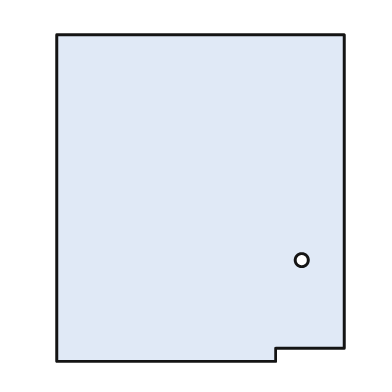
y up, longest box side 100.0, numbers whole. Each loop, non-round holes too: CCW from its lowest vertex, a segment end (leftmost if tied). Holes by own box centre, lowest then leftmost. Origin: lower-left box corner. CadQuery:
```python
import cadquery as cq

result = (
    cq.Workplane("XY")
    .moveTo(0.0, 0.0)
    .lineTo(67.0, 0.0)
    .lineTo(67.0, 4.0)
    .lineTo(88.0, 4.0)
    .lineTo(88.0, 100.0)
    .lineTo(0.0, 100.0)
    .close()
    .moveTo(75.0, 31.0)
    .circle(2.0)
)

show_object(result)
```